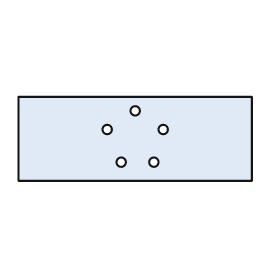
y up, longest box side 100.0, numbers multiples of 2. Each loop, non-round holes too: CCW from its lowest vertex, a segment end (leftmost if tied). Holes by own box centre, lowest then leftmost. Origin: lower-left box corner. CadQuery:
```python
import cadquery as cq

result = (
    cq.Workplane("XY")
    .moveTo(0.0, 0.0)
    .lineTo(100.0, 0.0)
    .lineTo(100.0, 36.0)
    .lineTo(0.0, 36.0)
    .close()
    .moveTo(44.0, 8.0)
    .circle(2.0)
    .moveTo(58.0, 8.0)
    .circle(2.0)
    .moveTo(38.0, 22.0)
    .circle(2.0)
    .moveTo(62.0, 22.0)
    .circle(2.0)
    .moveTo(50.0, 30.0)
    .circle(2.0)
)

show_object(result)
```